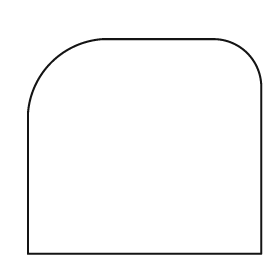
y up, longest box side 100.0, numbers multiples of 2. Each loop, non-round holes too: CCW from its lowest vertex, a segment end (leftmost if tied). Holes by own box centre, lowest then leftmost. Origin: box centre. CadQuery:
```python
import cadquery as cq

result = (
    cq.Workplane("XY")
    .moveTo(-50.0, -46.0)
    .lineTo(50.0, -46.0)
    .lineTo(50.0, 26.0)
    .threePointArc((44.0, 40.0), (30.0, 46.0))
    .lineTo(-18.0, 46.0)
    .threePointArc((-40.0, 36.0), (-50.0, 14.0))
    .close()
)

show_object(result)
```